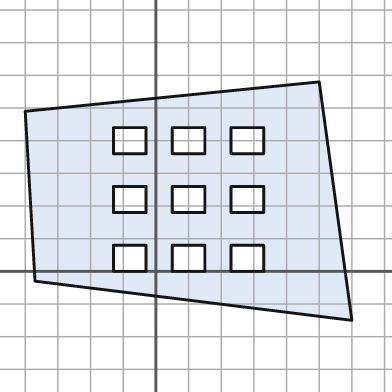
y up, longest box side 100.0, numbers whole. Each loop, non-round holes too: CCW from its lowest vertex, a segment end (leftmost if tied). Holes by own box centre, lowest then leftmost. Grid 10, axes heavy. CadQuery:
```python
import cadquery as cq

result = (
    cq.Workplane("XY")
    .moveTo(60.0, -15.0)
    .lineTo(50.0, 58.0)
    .lineTo(-40.0, 49.0)
    .lineTo(-37.0, -3.0)
    .close()
    .moveTo(-13.0, 0.0)
    .lineTo(-3.0, 0.0)
    .lineTo(-3.0, 8.0)
    .lineTo(-13.0, 8.0)
    .close()
    .moveTo(5.0, 0.0)
    .lineTo(15.0, 0.0)
    .lineTo(15.0, 8.0)
    .lineTo(5.0, 8.0)
    .close()
    .moveTo(23.0, 0.0)
    .lineTo(33.0, 0.0)
    .lineTo(33.0, 8.0)
    .lineTo(23.0, 8.0)
    .close()
    .moveTo(-13.0, 18.0)
    .lineTo(-3.0, 18.0)
    .lineTo(-3.0, 26.0)
    .lineTo(-13.0, 26.0)
    .close()
    .moveTo(5.0, 18.0)
    .lineTo(15.0, 18.0)
    .lineTo(15.0, 26.0)
    .lineTo(5.0, 26.0)
    .close()
    .moveTo(23.0, 18.0)
    .lineTo(33.0, 18.0)
    .lineTo(33.0, 26.0)
    .lineTo(23.0, 26.0)
    .close()
    .moveTo(-13.0, 36.0)
    .lineTo(-3.0, 36.0)
    .lineTo(-3.0, 44.0)
    .lineTo(-13.0, 44.0)
    .close()
    .moveTo(5.0, 36.0)
    .lineTo(15.0, 36.0)
    .lineTo(15.0, 44.0)
    .lineTo(5.0, 44.0)
    .close()
    .moveTo(23.0, 36.0)
    .lineTo(33.0, 36.0)
    .lineTo(33.0, 44.0)
    .lineTo(23.0, 44.0)
    .close()
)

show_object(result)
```